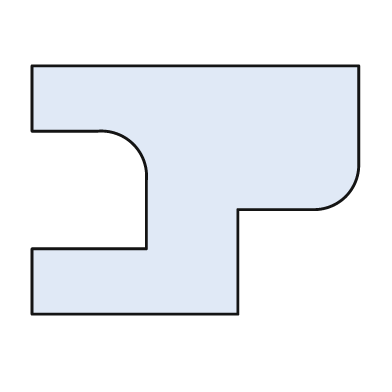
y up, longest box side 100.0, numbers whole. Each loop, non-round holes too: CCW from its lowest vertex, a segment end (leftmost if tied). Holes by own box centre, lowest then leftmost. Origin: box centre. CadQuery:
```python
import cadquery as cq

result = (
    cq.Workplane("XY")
    .moveTo(-50.0, -38.0)
    .lineTo(13.0, -38.0)
    .lineTo(13.0, -6.0)
    .lineTo(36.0, -6.0)
    .threePointArc((46.0, -2.0), (50.0, 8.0))
    .lineTo(50.0, 38.0)
    .lineTo(-50.0, 38.0)
    .lineTo(-50.0, 18.0)
    .lineTo(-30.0, 18.0)
    .threePointArc((-19.0, 14.0), (-15.0, 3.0))
    .lineTo(-15.0, -18.0)
    .lineTo(-50.0, -18.0)
    .close()
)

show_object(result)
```